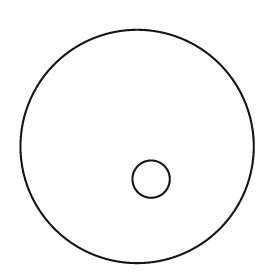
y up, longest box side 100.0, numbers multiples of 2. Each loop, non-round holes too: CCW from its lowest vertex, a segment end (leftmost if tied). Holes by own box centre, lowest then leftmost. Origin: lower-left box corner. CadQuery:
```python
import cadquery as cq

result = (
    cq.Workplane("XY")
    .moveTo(50.0, 50.0)
    .circle(50.0)
    .moveTo(56.0, 36.0)
    .circle(8.0)
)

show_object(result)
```